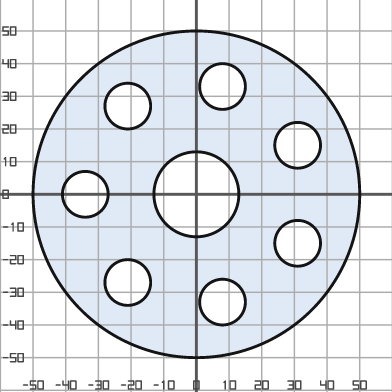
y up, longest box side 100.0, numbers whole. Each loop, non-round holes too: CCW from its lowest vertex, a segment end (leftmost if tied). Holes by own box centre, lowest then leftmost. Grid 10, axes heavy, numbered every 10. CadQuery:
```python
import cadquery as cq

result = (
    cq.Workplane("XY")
    .moveTo(0.0, 0.0)
    .circle(50.0)
    .moveTo(8.0, -33.0)
    .circle(7.0)
    .moveTo(-21.0, -27.0)
    .circle(7.0)
    .moveTo(31.0, -15.0)
    .circle(7.0)
    .moveTo(-34.0, 0.0)
    .circle(7.0)
    .moveTo(0.0, 0.0)
    .circle(13.0)
    .moveTo(31.0, 15.0)
    .circle(7.0)
    .moveTo(-21.0, 27.0)
    .circle(7.0)
    .moveTo(8.0, 33.0)
    .circle(7.0)
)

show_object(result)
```